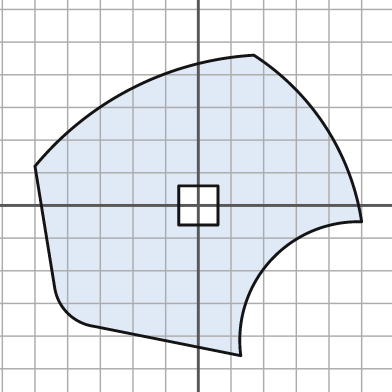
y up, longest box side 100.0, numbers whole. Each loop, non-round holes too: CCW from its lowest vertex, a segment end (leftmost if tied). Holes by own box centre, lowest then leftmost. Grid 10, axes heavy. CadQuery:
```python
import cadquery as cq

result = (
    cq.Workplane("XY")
    .moveTo(13.0, -46.0)
    .threePointArc((22.0, -17.0), (50.0, -5.0))
    .threePointArc((39.0, 24.0), (17.0, 46.0))
    .threePointArc((-20.0, 36.0), (-50.0, 12.0))
    .lineTo(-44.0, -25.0)
    .threePointArc((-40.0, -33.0), (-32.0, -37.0))
    .close()
    .moveTo(-6.0, -6.0)
    .lineTo(6.0, -6.0)
    .lineTo(6.0, 6.0)
    .lineTo(-6.0, 6.0)
    .close()
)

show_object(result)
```